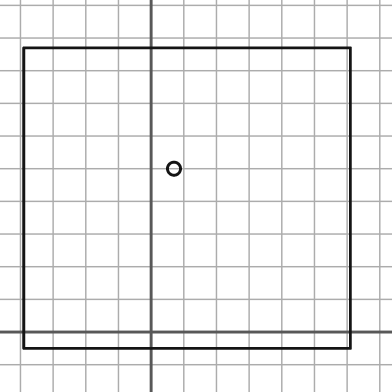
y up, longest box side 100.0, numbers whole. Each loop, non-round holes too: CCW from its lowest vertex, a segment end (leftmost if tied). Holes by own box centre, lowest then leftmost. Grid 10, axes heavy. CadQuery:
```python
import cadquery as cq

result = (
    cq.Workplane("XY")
    .moveTo(-39.0, -5.0)
    .lineTo(61.0, -5.0)
    .lineTo(61.0, 87.0)
    .lineTo(-39.0, 87.0)
    .close()
    .moveTo(7.0, 50.0)
    .circle(2.0)
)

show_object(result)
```